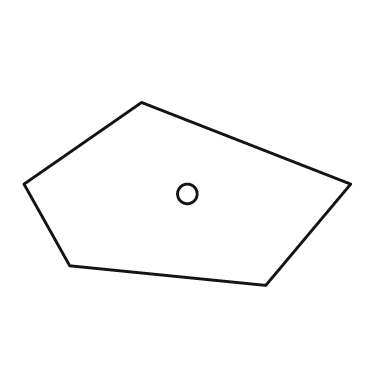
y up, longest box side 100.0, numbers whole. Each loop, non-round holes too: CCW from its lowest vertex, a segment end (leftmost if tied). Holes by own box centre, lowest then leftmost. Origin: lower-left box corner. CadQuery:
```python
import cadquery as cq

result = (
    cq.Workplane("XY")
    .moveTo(74.0, 0.0)
    .lineTo(100.0, 31.0)
    .lineTo(36.0, 56.0)
    .lineTo(0.0, 31.0)
    .lineTo(14.0, 6.0)
    .close()
    .moveTo(50.0, 28.0)
    .circle(3.0)
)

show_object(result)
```